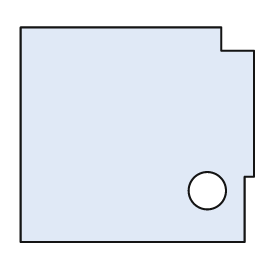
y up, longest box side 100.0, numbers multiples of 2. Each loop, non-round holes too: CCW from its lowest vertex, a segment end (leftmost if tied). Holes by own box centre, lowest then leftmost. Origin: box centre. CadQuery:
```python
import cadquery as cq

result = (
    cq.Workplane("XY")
    .moveTo(-50.0, -46.0)
    .lineTo(46.0, -46.0)
    .lineTo(46.0, -18.0)
    .lineTo(50.0, -18.0)
    .lineTo(50.0, 36.0)
    .lineTo(36.0, 36.0)
    .lineTo(36.0, 46.0)
    .lineTo(-50.0, 46.0)
    .close()
    .moveTo(30.0, -24.0)
    .circle(8.0)
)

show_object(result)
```